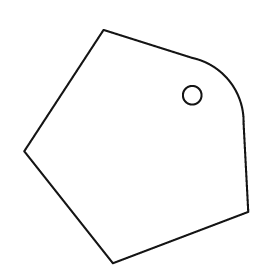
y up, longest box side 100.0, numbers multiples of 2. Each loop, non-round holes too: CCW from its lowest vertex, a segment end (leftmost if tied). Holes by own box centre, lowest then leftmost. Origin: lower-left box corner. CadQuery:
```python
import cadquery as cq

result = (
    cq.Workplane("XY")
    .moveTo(38.0, 0.0)
    .lineTo(96.0, 22.0)
    .lineTo(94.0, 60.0)
    .threePointArc((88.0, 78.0), (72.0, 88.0))
    .lineTo(34.0, 100.0)
    .lineTo(0.0, 48.0)
    .close()
    .moveTo(72.0, 72.0)
    .circle(4.0)
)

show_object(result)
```